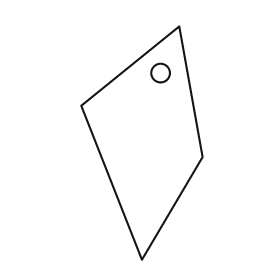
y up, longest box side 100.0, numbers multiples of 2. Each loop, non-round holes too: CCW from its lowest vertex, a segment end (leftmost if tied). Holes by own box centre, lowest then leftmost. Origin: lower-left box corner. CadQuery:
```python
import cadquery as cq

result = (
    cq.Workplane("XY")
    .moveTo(26.0, 0.0)
    .lineTo(52.0, 44.0)
    .lineTo(42.0, 100.0)
    .lineTo(0.0, 66.0)
    .close()
    .moveTo(34.0, 80.0)
    .circle(4.0)
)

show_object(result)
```